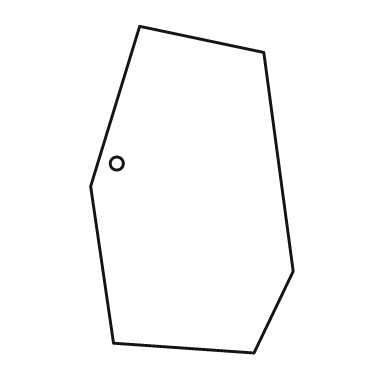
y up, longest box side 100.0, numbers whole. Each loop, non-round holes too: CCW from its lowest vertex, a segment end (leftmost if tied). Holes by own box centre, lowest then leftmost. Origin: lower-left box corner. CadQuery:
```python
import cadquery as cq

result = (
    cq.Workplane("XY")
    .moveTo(50.0, 0.0)
    .lineTo(62.0, 25.0)
    .lineTo(53.0, 92.0)
    .lineTo(15.0, 100.0)
    .lineTo(0.0, 51.0)
    .lineTo(7.0, 3.0)
    .close()
    .moveTo(8.0, 58.0)
    .circle(2.0)
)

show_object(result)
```